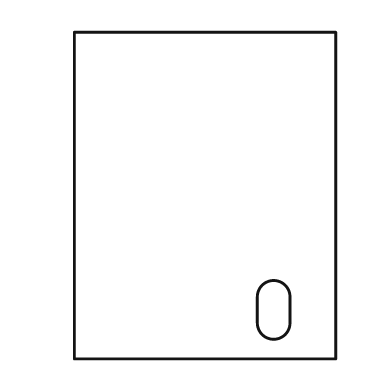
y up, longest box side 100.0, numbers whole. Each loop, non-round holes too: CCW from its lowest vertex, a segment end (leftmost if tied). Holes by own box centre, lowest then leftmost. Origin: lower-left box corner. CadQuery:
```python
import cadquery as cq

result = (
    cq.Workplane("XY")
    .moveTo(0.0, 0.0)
    .lineTo(80.0, 0.0)
    .lineTo(80.0, 100.0)
    .lineTo(0.0, 100.0)
    .close()
    .moveTo(56.0, 11.0)
    .threePointArc((61.0, 6.0), (66.0, 11.0))
    .lineTo(66.0, 19.0)
    .threePointArc((61.0, 24.0), (56.0, 19.0))
    .close()
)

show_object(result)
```